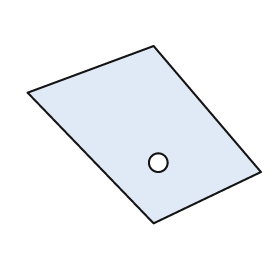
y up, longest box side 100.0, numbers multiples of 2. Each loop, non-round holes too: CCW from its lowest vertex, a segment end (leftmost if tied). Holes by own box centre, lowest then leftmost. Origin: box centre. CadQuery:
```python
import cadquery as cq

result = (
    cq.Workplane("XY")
    .moveTo(4.0, -38.0)
    .lineTo(50.0, -16.0)
    .lineTo(4.0, 38.0)
    .lineTo(-50.0, 18.0)
    .close()
    .moveTo(6.0, -12.0)
    .circle(4.0)
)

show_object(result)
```